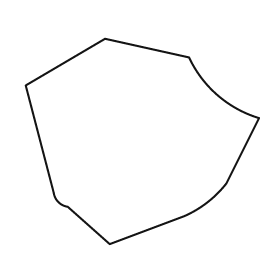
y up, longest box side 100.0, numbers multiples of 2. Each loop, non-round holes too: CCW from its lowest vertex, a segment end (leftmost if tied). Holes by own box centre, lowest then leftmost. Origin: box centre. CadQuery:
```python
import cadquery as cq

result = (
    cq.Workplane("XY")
    .moveTo(-14.0, -44.0)
    .lineTo(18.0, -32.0)
    .threePointArc((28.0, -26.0), (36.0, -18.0))
    .lineTo(50.0, 10.0)
    .threePointArc((32.0, 20.0), (20.0, 36.0))
    .lineTo(-16.0, 44.0)
    .lineTo(-50.0, 24.0)
    .lineTo(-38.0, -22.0)
    .threePointArc((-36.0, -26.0), (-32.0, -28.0))
    .close()
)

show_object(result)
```